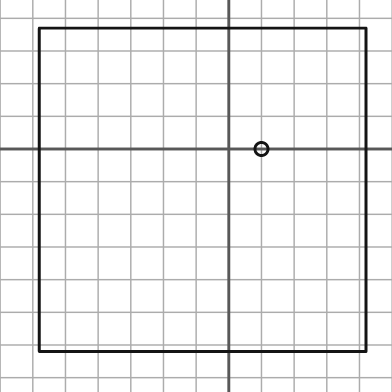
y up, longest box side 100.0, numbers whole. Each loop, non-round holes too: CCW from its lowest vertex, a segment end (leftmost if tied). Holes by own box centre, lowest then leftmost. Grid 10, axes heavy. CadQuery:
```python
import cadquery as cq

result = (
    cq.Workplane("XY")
    .moveTo(-58.0, -62.0)
    .lineTo(42.0, -62.0)
    .lineTo(42.0, 37.0)
    .lineTo(-58.0, 37.0)
    .close()
    .moveTo(10.0, 0.0)
    .circle(2.0)
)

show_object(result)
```